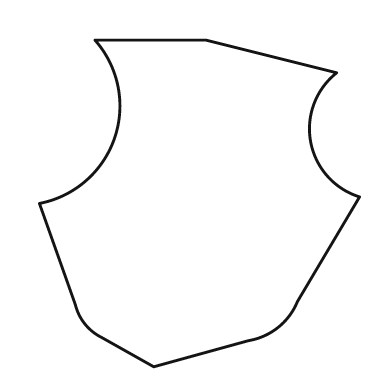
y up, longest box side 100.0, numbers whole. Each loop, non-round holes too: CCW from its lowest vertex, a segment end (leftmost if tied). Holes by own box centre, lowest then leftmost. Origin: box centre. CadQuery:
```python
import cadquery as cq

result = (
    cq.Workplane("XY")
    .moveTo(-14.0, -50.0)
    .lineTo(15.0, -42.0)
    .threePointArc((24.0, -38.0), (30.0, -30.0))
    .lineTo(49.0, 2.0)
    .threePointArc((34.0, 19.0), (42.0, 40.0))
    .lineTo(2.0, 50.0)
    .lineTo(-32.0, 50.0)
    .threePointArc((-26.0, 20.0), (-49.0, 0.0))
    .lineTo(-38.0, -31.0)
    .threePointArc((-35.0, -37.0), (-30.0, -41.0))
    .close()
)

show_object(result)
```